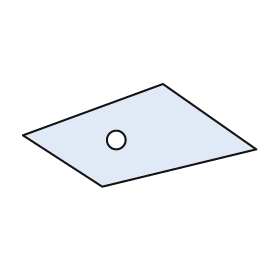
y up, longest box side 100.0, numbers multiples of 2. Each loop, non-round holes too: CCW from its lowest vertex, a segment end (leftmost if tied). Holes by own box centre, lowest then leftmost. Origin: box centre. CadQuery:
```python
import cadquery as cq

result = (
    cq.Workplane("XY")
    .moveTo(-16.0, -22.0)
    .lineTo(50.0, -6.0)
    .lineTo(10.0, 22.0)
    .lineTo(-50.0, 0.0)
    .close()
    .moveTo(-10.0, -2.0)
    .circle(4.0)
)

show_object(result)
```